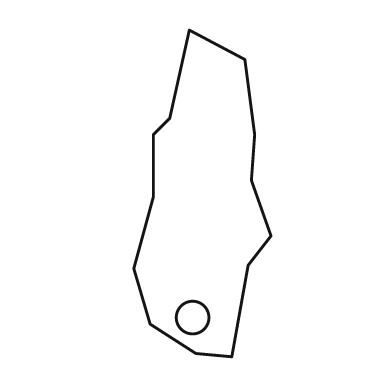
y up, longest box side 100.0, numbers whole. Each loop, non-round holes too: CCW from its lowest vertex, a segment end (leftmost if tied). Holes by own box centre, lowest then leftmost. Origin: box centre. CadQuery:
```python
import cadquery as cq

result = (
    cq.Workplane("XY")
    .moveTo(9.0, -50.0)
    .lineTo(14.0, -22.0)
    .lineTo(21.0, -13.0)
    .lineTo(15.0, 4.0)
    .lineTo(16.0, 18.0)
    .lineTo(13.0, 41.0)
    .lineTo(-4.0, 50.0)
    .lineTo(-10.0, 23.0)
    .lineTo(-15.0, 18.0)
    .lineTo(-15.0, -1.0)
    .lineTo(-21.0, -23.0)
    .lineTo(-16.0, -40.0)
    .lineTo(-2.0, -49.0)
    .close()
    .moveTo(-3.0, -38.0)
    .circle(5.0)
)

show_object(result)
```